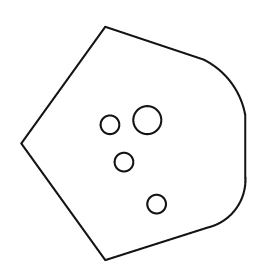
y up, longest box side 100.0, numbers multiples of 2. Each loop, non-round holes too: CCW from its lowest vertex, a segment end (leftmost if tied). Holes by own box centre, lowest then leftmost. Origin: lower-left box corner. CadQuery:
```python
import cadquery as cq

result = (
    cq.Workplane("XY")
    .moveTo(36.0, 0.0)
    .lineTo(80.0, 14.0)
    .threePointArc((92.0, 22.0), (96.0, 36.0))
    .lineTo(96.0, 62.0)
    .threePointArc((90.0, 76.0), (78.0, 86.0))
    .lineTo(36.0, 100.0)
    .lineTo(0.0, 50.0)
    .close()
    .moveTo(58.0, 24.0)
    .circle(4.0)
    .moveTo(44.0, 42.0)
    .circle(4.0)
    .moveTo(38.0, 58.0)
    .circle(4.0)
    .moveTo(54.0, 60.0)
    .circle(6.0)
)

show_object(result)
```